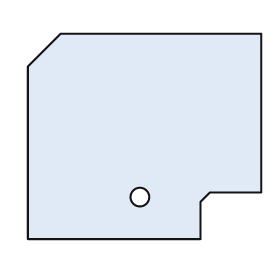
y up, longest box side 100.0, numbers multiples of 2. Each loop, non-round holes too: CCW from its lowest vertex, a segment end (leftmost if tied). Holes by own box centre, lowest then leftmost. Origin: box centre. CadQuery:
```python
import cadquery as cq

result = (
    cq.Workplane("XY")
    .moveTo(-50.0, -44.0)
    .lineTo(24.0, -44.0)
    .lineTo(24.0, -28.0)
    .lineTo(28.0, -24.0)
    .lineTo(50.0, -24.0)
    .lineTo(50.0, 44.0)
    .lineTo(-36.0, 44.0)
    .lineTo(-50.0, 30.0)
    .close()
    .moveTo(-2.0, -26.0)
    .circle(4.0)
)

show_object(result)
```